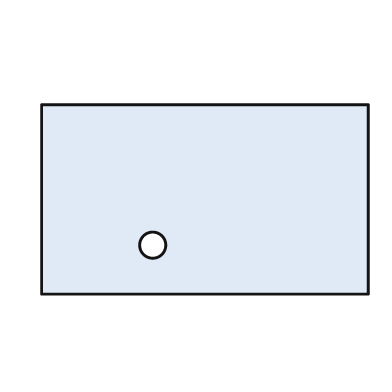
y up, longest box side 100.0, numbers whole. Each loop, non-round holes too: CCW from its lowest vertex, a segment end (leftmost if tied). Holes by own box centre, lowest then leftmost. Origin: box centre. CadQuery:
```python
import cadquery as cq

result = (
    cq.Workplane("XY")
    .moveTo(-50.0, -29.0)
    .lineTo(50.0, -29.0)
    .lineTo(50.0, 29.0)
    .lineTo(-50.0, 29.0)
    .close()
    .moveTo(-16.0, -14.0)
    .circle(4.0)
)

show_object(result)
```